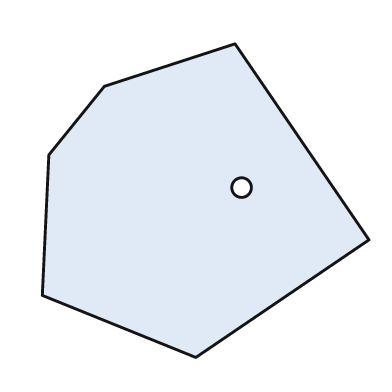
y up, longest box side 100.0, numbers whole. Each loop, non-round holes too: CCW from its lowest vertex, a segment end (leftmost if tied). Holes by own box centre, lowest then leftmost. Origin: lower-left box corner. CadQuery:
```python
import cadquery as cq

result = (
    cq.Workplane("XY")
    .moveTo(47.0, 0.0)
    .lineTo(100.0, 36.0)
    .lineTo(59.0, 96.0)
    .lineTo(19.0, 83.0)
    .lineTo(2.0, 62.0)
    .lineTo(0.0, 19.0)
    .close()
    .moveTo(61.0, 52.0)
    .circle(3.0)
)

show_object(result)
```